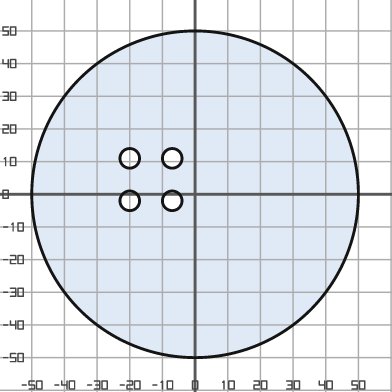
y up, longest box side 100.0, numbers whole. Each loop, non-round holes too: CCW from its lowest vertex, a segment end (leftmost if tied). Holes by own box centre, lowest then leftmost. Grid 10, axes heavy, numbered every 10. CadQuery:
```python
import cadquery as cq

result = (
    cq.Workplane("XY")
    .moveTo(0.0, 0.0)
    .circle(50.0)
    .moveTo(-20.0, -2.0)
    .circle(3.0)
    .moveTo(-7.0, -2.0)
    .circle(3.0)
    .moveTo(-20.0, 11.0)
    .circle(3.0)
    .moveTo(-7.0, 11.0)
    .circle(3.0)
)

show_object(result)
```